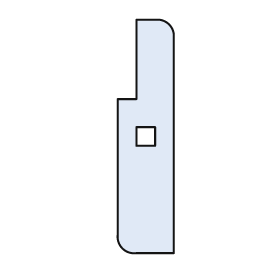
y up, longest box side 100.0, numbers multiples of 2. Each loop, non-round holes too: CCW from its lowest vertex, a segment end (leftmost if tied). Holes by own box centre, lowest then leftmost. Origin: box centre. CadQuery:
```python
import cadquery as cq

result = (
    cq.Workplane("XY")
    .moveTo(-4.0, -50.0)
    .lineTo(12.0, -50.0)
    .lineTo(12.0, 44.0)
    .threePointArc((10.0, 48.0), (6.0, 50.0))
    .lineTo(-4.0, 50.0)
    .lineTo(-4.0, 16.0)
    .lineTo(-12.0, 16.0)
    .lineTo(-12.0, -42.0)
    .threePointArc((-10.0, -48.0), (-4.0, -50.0))
    .close()
    .moveTo(-4.0, -4.0)
    .lineTo(4.0, -4.0)
    .lineTo(4.0, 4.0)
    .lineTo(-4.0, 4.0)
    .close()
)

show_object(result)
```